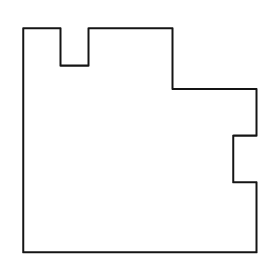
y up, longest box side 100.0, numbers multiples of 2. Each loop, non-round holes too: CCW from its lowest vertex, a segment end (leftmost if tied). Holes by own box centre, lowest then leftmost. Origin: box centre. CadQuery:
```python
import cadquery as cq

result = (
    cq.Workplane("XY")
    .moveTo(-50.0, -48.0)
    .lineTo(50.0, -48.0)
    .lineTo(50.0, -18.0)
    .lineTo(40.0, -18.0)
    .lineTo(40.0, 2.0)
    .lineTo(50.0, 2.0)
    .lineTo(50.0, 22.0)
    .lineTo(14.0, 22.0)
    .lineTo(14.0, 48.0)
    .lineTo(-22.0, 48.0)
    .lineTo(-22.0, 32.0)
    .lineTo(-34.0, 32.0)
    .lineTo(-34.0, 48.0)
    .lineTo(-50.0, 48.0)
    .close()
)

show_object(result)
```